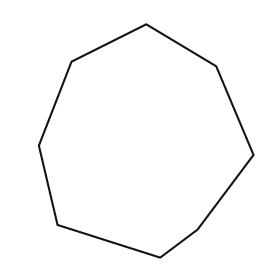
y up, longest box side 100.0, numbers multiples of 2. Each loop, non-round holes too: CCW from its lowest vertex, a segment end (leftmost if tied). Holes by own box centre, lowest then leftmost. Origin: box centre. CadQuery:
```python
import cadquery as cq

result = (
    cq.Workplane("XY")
    .moveTo(6.0, -50.0)
    .lineTo(22.0, -38.0)
    .lineTo(46.0, -6.0)
    .lineTo(30.0, 32.0)
    .lineTo(0.0, 50.0)
    .lineTo(-32.0, 34.0)
    .lineTo(-46.0, -2.0)
    .lineTo(-38.0, -36.0)
    .close()
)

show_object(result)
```